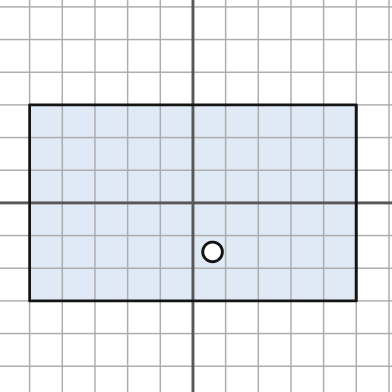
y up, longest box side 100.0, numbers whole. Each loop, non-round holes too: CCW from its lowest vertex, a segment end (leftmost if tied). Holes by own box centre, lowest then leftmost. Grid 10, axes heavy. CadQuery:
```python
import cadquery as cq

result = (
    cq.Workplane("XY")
    .moveTo(-50.0, -30.0)
    .lineTo(50.0, -30.0)
    .lineTo(50.0, 30.0)
    .lineTo(-50.0, 30.0)
    .close()
    .moveTo(6.0, -15.0)
    .circle(3.0)
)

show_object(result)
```